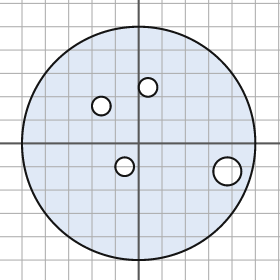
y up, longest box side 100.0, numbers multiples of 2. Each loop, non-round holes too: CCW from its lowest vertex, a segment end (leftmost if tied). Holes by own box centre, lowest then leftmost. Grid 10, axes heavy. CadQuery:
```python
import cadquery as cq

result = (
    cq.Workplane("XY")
    .moveTo(0.0, 0.0)
    .circle(50.0)
    .moveTo(38.0, -12.0)
    .circle(6.0)
    .moveTo(-6.0, -10.0)
    .circle(4.0)
    .moveTo(-16.0, 16.0)
    .circle(4.0)
    .moveTo(4.0, 24.0)
    .circle(4.0)
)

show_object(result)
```